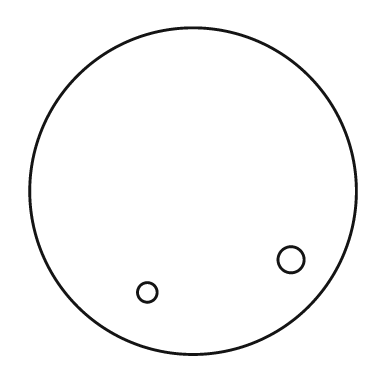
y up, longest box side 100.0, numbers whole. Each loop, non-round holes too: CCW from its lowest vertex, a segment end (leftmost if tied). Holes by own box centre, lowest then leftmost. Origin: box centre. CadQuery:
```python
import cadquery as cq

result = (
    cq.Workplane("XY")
    .moveTo(0.0, 0.0)
    .circle(50.0)
    .moveTo(-14.0, -31.0)
    .circle(3.0)
    .moveTo(30.0, -21.0)
    .circle(4.0)
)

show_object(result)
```